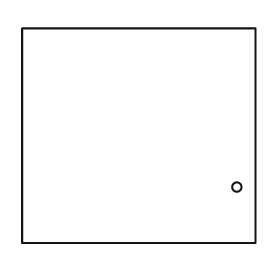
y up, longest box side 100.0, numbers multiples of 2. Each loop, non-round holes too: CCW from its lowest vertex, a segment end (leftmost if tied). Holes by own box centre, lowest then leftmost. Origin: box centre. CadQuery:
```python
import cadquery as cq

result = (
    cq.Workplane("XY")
    .moveTo(-50.0, -46.0)
    .lineTo(50.0, -46.0)
    .lineTo(50.0, 46.0)
    .lineTo(-50.0, 46.0)
    .close()
    .moveTo(42.0, -22.0)
    .circle(2.0)
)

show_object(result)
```